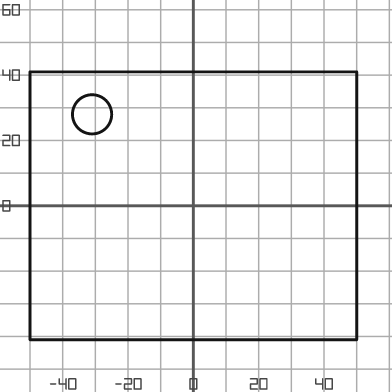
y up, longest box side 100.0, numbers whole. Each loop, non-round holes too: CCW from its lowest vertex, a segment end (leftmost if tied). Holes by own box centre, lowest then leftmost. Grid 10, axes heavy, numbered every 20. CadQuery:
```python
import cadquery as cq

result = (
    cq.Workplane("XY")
    .moveTo(-50.0, -41.0)
    .lineTo(50.0, -41.0)
    .lineTo(50.0, 41.0)
    .lineTo(-50.0, 41.0)
    .close()
    .moveTo(-31.0, 28.0)
    .circle(6.0)
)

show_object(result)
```